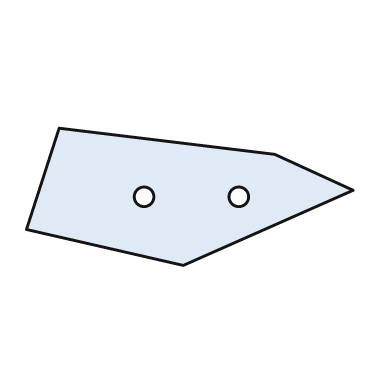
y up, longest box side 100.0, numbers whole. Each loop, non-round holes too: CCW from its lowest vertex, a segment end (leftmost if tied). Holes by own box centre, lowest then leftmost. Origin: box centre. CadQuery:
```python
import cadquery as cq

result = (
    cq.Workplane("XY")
    .moveTo(-2.0, -21.0)
    .lineTo(50.0, 2.0)
    .lineTo(26.0, 13.0)
    .lineTo(-40.0, 21.0)
    .lineTo(-50.0, -10.0)
    .close()
    .moveTo(-14.0, 0.0)
    .circle(3.0)
    .moveTo(15.0, 0.0)
    .circle(3.0)
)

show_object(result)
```